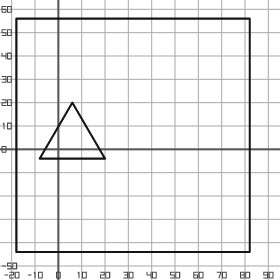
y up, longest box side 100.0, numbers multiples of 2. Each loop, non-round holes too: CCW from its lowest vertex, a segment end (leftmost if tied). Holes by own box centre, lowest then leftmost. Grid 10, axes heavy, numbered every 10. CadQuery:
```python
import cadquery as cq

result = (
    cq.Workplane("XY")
    .moveTo(-18.0, -44.0)
    .lineTo(82.0, -44.0)
    .lineTo(82.0, 56.0)
    .lineTo(-18.0, 56.0)
    .close()
    .moveTo(-8.0, -4.0)
    .lineTo(20.0, -4.0)
    .lineTo(6.0, 20.0)
    .close()
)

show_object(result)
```